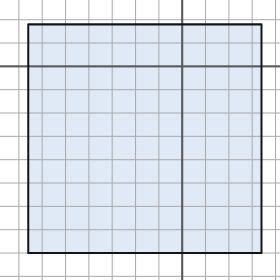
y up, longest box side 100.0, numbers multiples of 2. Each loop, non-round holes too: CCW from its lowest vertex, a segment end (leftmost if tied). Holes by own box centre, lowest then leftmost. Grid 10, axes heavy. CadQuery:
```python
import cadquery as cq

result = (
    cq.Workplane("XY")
    .moveTo(-66.0, -80.0)
    .lineTo(34.0, -80.0)
    .lineTo(34.0, 18.0)
    .lineTo(-66.0, 18.0)
    .close()
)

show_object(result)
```